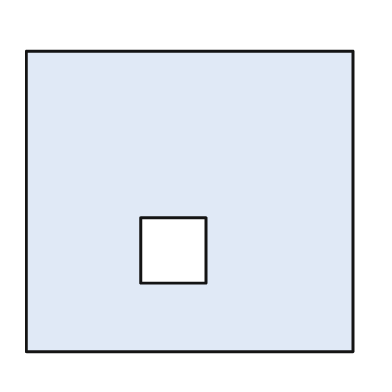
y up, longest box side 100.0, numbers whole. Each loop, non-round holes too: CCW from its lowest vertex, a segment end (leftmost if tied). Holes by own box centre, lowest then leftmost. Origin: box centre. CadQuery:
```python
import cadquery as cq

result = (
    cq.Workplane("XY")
    .moveTo(-50.0, -46.0)
    .lineTo(50.0, -46.0)
    .lineTo(50.0, 46.0)
    .lineTo(-50.0, 46.0)
    .close()
    .moveTo(-15.0, -25.0)
    .lineTo(5.0, -25.0)
    .lineTo(5.0, -5.0)
    .lineTo(-15.0, -5.0)
    .close()
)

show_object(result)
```